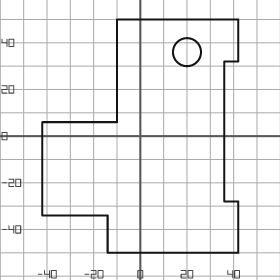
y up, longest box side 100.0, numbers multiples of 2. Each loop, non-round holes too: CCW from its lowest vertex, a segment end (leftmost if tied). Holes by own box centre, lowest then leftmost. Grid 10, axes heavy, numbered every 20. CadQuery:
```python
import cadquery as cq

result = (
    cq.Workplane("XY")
    .moveTo(-14.0, -50.0)
    .lineTo(42.0, -50.0)
    .lineTo(42.0, -28.0)
    .lineTo(36.0, -28.0)
    .lineTo(36.0, 32.0)
    .lineTo(42.0, 32.0)
    .lineTo(42.0, 50.0)
    .lineTo(-10.0, 50.0)
    .lineTo(-10.0, 6.0)
    .lineTo(-42.0, 6.0)
    .lineTo(-42.0, -34.0)
    .lineTo(-14.0, -34.0)
    .close()
    .moveTo(20.0, 36.0)
    .circle(6.0)
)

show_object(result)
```